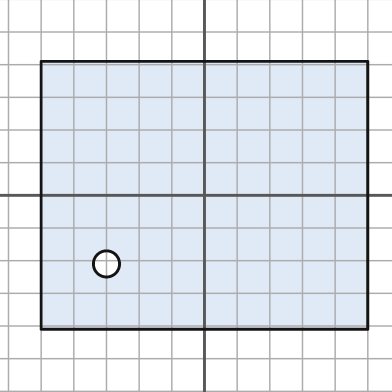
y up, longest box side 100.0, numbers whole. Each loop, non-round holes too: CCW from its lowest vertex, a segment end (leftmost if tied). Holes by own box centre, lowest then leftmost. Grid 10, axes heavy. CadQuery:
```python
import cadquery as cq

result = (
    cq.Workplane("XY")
    .moveTo(-50.0, -41.0)
    .lineTo(50.0, -41.0)
    .lineTo(50.0, 41.0)
    .lineTo(-50.0, 41.0)
    .close()
    .moveTo(-30.0, -21.0)
    .circle(4.0)
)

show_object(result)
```